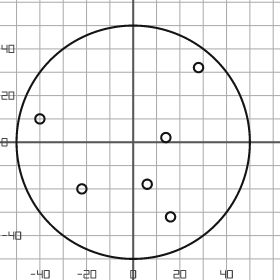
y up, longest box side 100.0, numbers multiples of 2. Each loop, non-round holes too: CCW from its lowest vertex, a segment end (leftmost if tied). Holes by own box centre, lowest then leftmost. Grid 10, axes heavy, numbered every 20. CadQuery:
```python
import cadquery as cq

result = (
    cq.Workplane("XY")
    .moveTo(0.0, 0.0)
    .circle(50.0)
    .moveTo(16.0, -32.0)
    .circle(2.0)
    .moveTo(-22.0, -20.0)
    .circle(2.0)
    .moveTo(6.0, -18.0)
    .circle(2.0)
    .moveTo(14.0, 2.0)
    .circle(2.0)
    .moveTo(-40.0, 10.0)
    .circle(2.0)
    .moveTo(28.0, 32.0)
    .circle(2.0)
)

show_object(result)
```